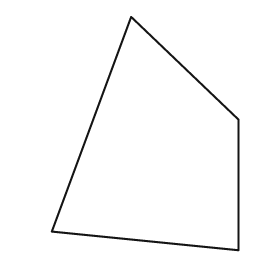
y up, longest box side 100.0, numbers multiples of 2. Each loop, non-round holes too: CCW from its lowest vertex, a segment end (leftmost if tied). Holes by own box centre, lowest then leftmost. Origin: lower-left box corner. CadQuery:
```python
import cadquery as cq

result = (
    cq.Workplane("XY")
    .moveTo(80.0, 0.0)
    .lineTo(80.0, 56.0)
    .lineTo(34.0, 100.0)
    .lineTo(0.0, 8.0)
    .close()
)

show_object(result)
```